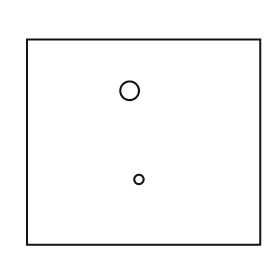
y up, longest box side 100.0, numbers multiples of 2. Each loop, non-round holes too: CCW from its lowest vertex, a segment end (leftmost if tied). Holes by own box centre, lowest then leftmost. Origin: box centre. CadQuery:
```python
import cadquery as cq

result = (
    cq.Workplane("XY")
    .moveTo(-50.0, -44.0)
    .lineTo(50.0, -44.0)
    .lineTo(50.0, 44.0)
    .lineTo(-50.0, 44.0)
    .close()
    .moveTo(-2.0, -16.0)
    .circle(2.0)
    .moveTo(-6.0, 22.0)
    .circle(4.0)
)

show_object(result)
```